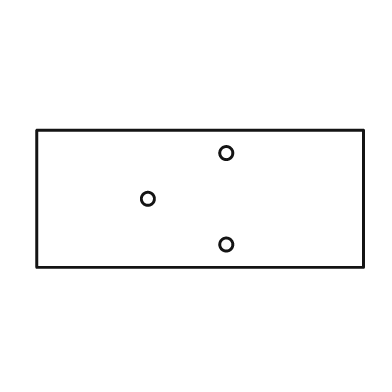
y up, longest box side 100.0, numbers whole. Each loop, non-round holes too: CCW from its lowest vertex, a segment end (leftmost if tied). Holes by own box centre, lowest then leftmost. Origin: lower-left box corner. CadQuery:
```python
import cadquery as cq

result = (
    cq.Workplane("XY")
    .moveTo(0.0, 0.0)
    .lineTo(100.0, 0.0)
    .lineTo(100.0, 42.0)
    .lineTo(0.0, 42.0)
    .close()
    .moveTo(58.0, 7.0)
    .circle(2.0)
    .moveTo(34.0, 21.0)
    .circle(2.0)
    .moveTo(58.0, 35.0)
    .circle(2.0)
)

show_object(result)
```